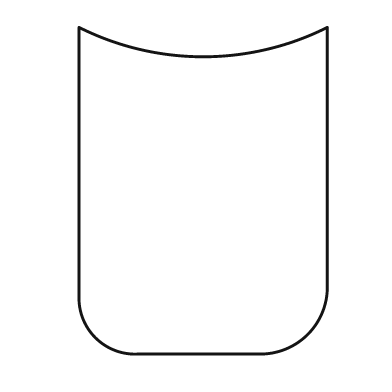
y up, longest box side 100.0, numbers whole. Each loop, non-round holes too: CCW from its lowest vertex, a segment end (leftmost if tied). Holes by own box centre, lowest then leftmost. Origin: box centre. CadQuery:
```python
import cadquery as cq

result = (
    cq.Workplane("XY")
    .moveTo(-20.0, -50.0)
    .lineTo(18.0, -50.0)
    .threePointArc((32.0, -44.0), (38.0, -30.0))
    .lineTo(38.0, 50.0)
    .threePointArc((0.0, 41.0), (-38.0, 50.0))
    .lineTo(-38.0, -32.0)
    .threePointArc((-33.0, -45.0), (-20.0, -50.0))
    .close()
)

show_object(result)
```